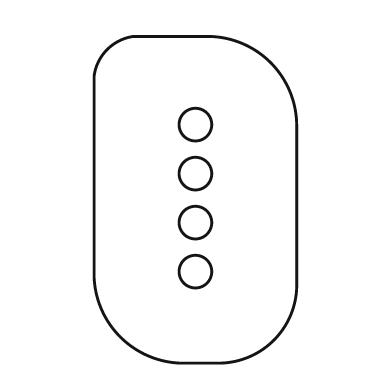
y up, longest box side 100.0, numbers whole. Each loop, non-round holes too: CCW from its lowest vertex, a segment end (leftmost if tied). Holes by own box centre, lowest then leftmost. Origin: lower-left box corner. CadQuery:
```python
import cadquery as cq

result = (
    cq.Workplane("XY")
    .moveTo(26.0, 0.0)
    .lineTo(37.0, 0.0)
    .threePointArc((55.0, 7.0), (62.0, 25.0))
    .lineTo(62.0, 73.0)
    .threePointArc((54.0, 92.0), (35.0, 100.0))
    .lineTo(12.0, 100.0)
    .threePointArc((4.0, 96.0), (0.0, 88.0))
    .lineTo(0.0, 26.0)
    .threePointArc((8.0, 8.0), (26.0, 0.0))
    .close()
    .moveTo(31.0, 28.0)
    .circle(5.0)
    .moveTo(31.0, 43.0)
    .circle(5.0)
    .moveTo(31.0, 58.0)
    .circle(5.0)
    .moveTo(31.0, 73.0)
    .circle(5.0)
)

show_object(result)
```